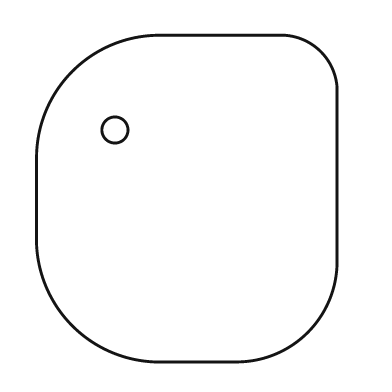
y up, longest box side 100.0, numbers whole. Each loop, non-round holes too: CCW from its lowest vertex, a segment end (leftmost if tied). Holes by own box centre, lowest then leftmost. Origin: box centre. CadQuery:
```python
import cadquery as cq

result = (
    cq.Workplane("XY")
    .moveTo(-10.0, -50.0)
    .lineTo(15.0, -50.0)
    .threePointArc((37.0, -41.0), (46.0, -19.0))
    .lineTo(46.0, 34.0)
    .threePointArc((41.0, 45.0), (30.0, 50.0))
    .lineTo(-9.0, 50.0)
    .threePointArc((-35.0, 39.0), (-46.0, 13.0))
    .lineTo(-46.0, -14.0)
    .threePointArc((-35.0, -39.0), (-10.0, -50.0))
    .close()
    .moveTo(-22.0, 21.0)
    .circle(4.0)
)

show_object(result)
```